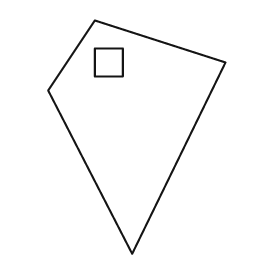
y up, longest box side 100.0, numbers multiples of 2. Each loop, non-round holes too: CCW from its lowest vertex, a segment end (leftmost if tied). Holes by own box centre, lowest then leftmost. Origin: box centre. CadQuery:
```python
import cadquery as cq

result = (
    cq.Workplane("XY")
    .moveTo(-2.0, -50.0)
    .lineTo(38.0, 32.0)
    .lineTo(-18.0, 50.0)
    .lineTo(-38.0, 20.0)
    .close()
    .moveTo(-18.0, 26.0)
    .lineTo(-6.0, 26.0)
    .lineTo(-6.0, 38.0)
    .lineTo(-18.0, 38.0)
    .close()
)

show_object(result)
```